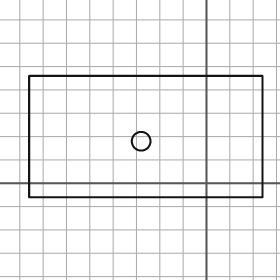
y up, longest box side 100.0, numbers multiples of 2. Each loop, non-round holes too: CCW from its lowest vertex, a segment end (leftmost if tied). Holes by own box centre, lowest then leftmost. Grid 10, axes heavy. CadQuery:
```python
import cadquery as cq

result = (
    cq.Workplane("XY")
    .moveTo(-76.0, -6.0)
    .lineTo(24.0, -6.0)
    .lineTo(24.0, 46.0)
    .lineTo(-76.0, 46.0)
    .close()
    .moveTo(-28.0, 18.0)
    .circle(4.0)
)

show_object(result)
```